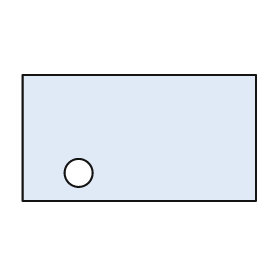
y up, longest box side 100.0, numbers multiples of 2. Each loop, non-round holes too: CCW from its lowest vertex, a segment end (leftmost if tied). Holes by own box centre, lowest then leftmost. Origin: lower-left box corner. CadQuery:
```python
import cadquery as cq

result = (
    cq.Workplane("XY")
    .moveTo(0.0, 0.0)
    .lineTo(100.0, 0.0)
    .lineTo(100.0, 54.0)
    .lineTo(0.0, 54.0)
    .close()
    .moveTo(24.0, 12.0)
    .circle(6.0)
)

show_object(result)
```